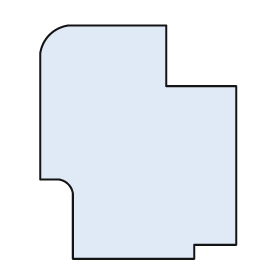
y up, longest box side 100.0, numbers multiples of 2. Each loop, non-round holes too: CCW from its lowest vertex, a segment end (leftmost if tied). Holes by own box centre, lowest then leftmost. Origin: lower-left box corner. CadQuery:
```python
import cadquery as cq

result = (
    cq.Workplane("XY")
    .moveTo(14.0, 0.0)
    .lineTo(66.0, 0.0)
    .lineTo(66.0, 6.0)
    .lineTo(84.0, 6.0)
    .lineTo(84.0, 74.0)
    .lineTo(54.0, 74.0)
    .lineTo(54.0, 100.0)
    .lineTo(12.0, 100.0)
    .threePointArc((4.0, 96.0), (0.0, 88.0))
    .lineTo(0.0, 34.0)
    .lineTo(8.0, 34.0)
    .threePointArc((12.0, 32.0), (14.0, 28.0))
    .close()
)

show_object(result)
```